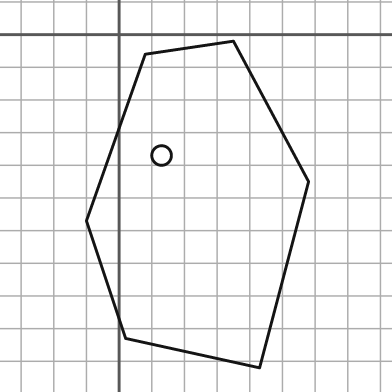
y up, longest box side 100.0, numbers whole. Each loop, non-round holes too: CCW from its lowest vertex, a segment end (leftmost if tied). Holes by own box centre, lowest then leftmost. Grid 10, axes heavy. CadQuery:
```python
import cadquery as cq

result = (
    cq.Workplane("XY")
    .moveTo(43.0, -102.0)
    .lineTo(58.0, -45.0)
    .lineTo(35.0, -2.0)
    .lineTo(8.0, -6.0)
    .lineTo(-10.0, -57.0)
    .lineTo(2.0, -93.0)
    .close()
    .moveTo(13.0, -37.0)
    .circle(3.0)
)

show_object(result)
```